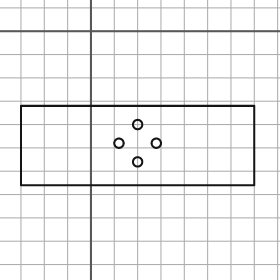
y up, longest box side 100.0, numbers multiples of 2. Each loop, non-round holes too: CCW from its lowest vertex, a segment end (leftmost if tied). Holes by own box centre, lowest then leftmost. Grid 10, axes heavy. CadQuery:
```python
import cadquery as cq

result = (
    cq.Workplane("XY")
    .moveTo(-30.0, -66.0)
    .lineTo(70.0, -66.0)
    .lineTo(70.0, -32.0)
    .lineTo(-30.0, -32.0)
    .close()
    .moveTo(20.0, -56.0)
    .circle(2.0)
    .moveTo(12.0, -48.0)
    .circle(2.0)
    .moveTo(28.0, -48.0)
    .circle(2.0)
    .moveTo(20.0, -40.0)
    .circle(2.0)
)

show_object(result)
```